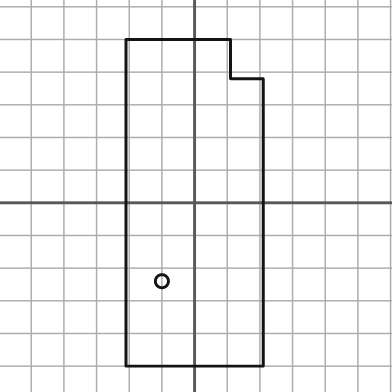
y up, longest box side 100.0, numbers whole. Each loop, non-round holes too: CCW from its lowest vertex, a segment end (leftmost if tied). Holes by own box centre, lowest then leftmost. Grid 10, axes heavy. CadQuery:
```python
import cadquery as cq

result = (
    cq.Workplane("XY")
    .moveTo(-21.0, -50.0)
    .lineTo(21.0, -50.0)
    .lineTo(21.0, 38.0)
    .lineTo(11.0, 38.0)
    .lineTo(11.0, 50.0)
    .lineTo(-21.0, 50.0)
    .close()
    .moveTo(-10.0, -24.0)
    .circle(2.0)
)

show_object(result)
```